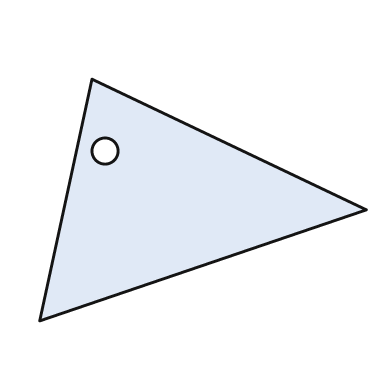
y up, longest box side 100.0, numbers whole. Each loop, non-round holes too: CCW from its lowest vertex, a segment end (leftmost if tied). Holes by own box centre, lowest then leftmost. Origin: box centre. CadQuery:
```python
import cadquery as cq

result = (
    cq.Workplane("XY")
    .moveTo(-50.0, -37.0)
    .lineTo(50.0, -3.0)
    .lineTo(-34.0, 37.0)
    .close()
    .moveTo(-30.0, 15.0)
    .circle(4.0)
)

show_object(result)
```